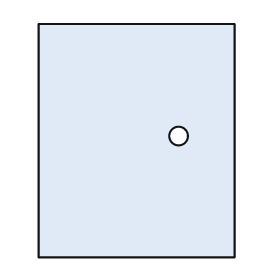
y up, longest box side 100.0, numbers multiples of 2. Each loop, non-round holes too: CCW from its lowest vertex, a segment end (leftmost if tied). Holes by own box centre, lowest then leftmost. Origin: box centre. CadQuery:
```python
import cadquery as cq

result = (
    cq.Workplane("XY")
    .moveTo(-42.0, -50.0)
    .lineTo(42.0, -50.0)
    .lineTo(42.0, 50.0)
    .lineTo(-42.0, 50.0)
    .close()
    .moveTo(18.0, 2.0)
    .circle(4.0)
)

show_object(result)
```